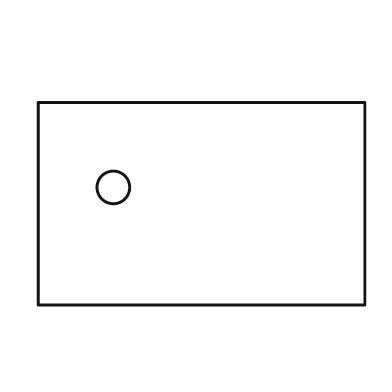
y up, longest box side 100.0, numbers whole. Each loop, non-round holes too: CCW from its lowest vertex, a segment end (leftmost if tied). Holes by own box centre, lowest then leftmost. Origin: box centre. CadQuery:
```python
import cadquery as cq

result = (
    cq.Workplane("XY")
    .moveTo(-50.0, -31.0)
    .lineTo(50.0, -31.0)
    .lineTo(50.0, 31.0)
    .lineTo(-50.0, 31.0)
    .close()
    .moveTo(-27.0, 5.0)
    .circle(5.0)
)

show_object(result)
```